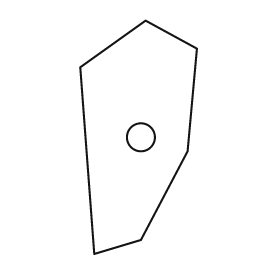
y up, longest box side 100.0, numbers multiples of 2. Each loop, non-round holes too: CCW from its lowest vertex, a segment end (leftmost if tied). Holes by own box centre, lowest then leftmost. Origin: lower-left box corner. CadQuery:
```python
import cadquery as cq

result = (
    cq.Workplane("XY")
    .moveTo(6.0, 0.0)
    .lineTo(26.0, 6.0)
    .lineTo(46.0, 44.0)
    .lineTo(50.0, 88.0)
    .lineTo(28.0, 100.0)
    .lineTo(0.0, 80.0)
    .close()
    .moveTo(26.0, 50.0)
    .circle(6.0)
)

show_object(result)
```